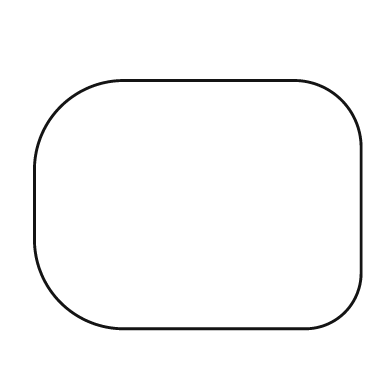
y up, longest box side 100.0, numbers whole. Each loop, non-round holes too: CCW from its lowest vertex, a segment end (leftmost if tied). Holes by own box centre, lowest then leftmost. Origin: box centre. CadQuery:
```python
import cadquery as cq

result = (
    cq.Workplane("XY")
    .moveTo(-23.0, -38.0)
    .lineTo(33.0, -38.0)
    .threePointArc((45.0, -33.0), (50.0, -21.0))
    .lineTo(50.0, 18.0)
    .threePointArc((44.0, 32.0), (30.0, 38.0))
    .lineTo(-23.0, 38.0)
    .threePointArc((-42.0, 30.0), (-50.0, 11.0))
    .lineTo(-50.0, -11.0)
    .threePointArc((-42.0, -30.0), (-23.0, -38.0))
    .close()
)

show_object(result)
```